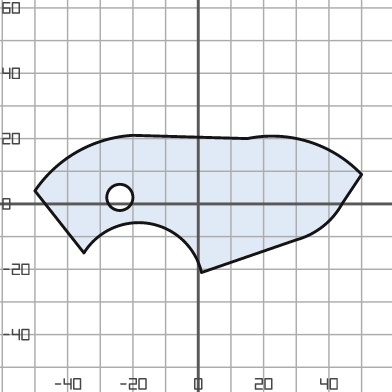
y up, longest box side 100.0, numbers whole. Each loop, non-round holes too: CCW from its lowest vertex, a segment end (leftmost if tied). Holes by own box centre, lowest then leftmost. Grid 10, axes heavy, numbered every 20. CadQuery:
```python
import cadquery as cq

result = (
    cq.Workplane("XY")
    .moveTo(1.0, -21.0)
    .lineTo(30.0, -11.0)
    .threePointArc((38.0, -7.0), (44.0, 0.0))
    .lineTo(50.0, 9.0)
    .threePointArc((34.0, 19.0), (15.0, 20.0))
    .lineTo(-20.0, 21.0)
    .threePointArc((-37.0, 16.0), (-50.0, 4.0))
    .lineTo(-35.0, -15.0)
    .threePointArc((-15.0, -6.0), (1.0, -21.0))
    .close()
    .moveTo(-24.0, 2.0)
    .circle(4.0)
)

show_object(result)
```